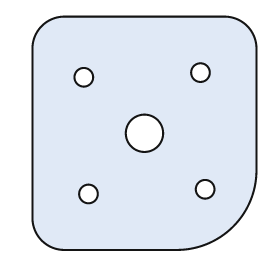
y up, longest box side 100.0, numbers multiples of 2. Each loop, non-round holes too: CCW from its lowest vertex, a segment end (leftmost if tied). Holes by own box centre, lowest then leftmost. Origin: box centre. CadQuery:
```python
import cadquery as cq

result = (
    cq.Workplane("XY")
    .moveTo(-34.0, -50.0)
    .lineTo(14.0, -50.0)
    .threePointArc((38.0, -40.0), (48.0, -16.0))
    .lineTo(48.0, 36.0)
    .threePointArc((44.0, 46.0), (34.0, 50.0))
    .lineTo(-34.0, 50.0)
    .threePointArc((-44.0, 46.0), (-48.0, 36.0))
    .lineTo(-48.0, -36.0)
    .threePointArc((-44.0, -46.0), (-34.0, -50.0))
    .close()
    .moveTo(-24.0, -26.0)
    .circle(4.0)
    .moveTo(26.0, -24.0)
    .circle(4.0)
    .moveTo(0.0, 0.0)
    .circle(8.0)
    .moveTo(-26.0, 24.0)
    .circle(4.0)
    .moveTo(24.0, 26.0)
    .circle(4.0)
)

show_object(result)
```